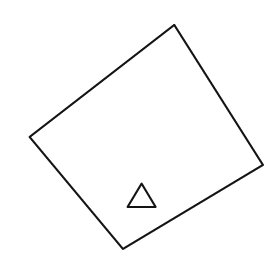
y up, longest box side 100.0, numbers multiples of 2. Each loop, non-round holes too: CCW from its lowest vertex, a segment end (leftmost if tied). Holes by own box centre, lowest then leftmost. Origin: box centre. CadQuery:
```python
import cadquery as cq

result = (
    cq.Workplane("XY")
    .moveTo(-10.0, -48.0)
    .lineTo(50.0, -12.0)
    .lineTo(12.0, 48.0)
    .lineTo(-50.0, 0.0)
    .close()
    .moveTo(-8.0, -30.0)
    .lineTo(4.0, -30.0)
    .lineTo(-2.0, -20.0)
    .close()
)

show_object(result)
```